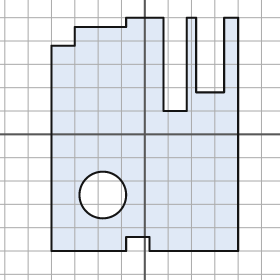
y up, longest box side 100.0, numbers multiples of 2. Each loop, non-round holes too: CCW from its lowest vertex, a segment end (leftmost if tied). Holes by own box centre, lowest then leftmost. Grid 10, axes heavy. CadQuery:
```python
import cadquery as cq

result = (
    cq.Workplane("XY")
    .moveTo(-40.0, -50.0)
    .lineTo(-8.0, -50.0)
    .lineTo(-8.0, -44.0)
    .lineTo(2.0, -44.0)
    .lineTo(2.0, -50.0)
    .lineTo(40.0, -50.0)
    .lineTo(40.0, 50.0)
    .lineTo(34.0, 50.0)
    .lineTo(34.0, 18.0)
    .lineTo(22.0, 18.0)
    .lineTo(22.0, 50.0)
    .lineTo(18.0, 50.0)
    .lineTo(18.0, 10.0)
    .lineTo(8.0, 10.0)
    .lineTo(8.0, 50.0)
    .lineTo(-8.0, 50.0)
    .lineTo(-8.0, 46.0)
    .lineTo(-30.0, 46.0)
    .lineTo(-30.0, 38.0)
    .lineTo(-40.0, 38.0)
    .close()
    .moveTo(-18.0, -26.0)
    .circle(10.0)
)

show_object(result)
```